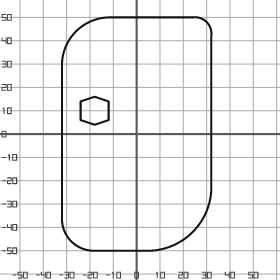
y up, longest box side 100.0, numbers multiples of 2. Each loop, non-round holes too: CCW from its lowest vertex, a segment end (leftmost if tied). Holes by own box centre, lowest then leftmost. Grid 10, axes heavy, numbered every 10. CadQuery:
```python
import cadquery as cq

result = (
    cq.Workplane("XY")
    .moveTo(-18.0, -50.0)
    .lineTo(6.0, -50.0)
    .threePointArc((24.0, -42.0), (32.0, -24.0))
    .lineTo(32.0, 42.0)
    .threePointArc((30.0, 48.0), (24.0, 50.0))
    .lineTo(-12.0, 50.0)
    .threePointArc((-26.0, 44.0), (-32.0, 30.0))
    .lineTo(-32.0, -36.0)
    .threePointArc((-28.0, -46.0), (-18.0, -50.0))
    .close()
    .moveTo(-18.0, 4.0)
    .lineTo(-12.0, 6.0)
    .lineTo(-12.0, 14.0)
    .lineTo(-18.0, 16.0)
    .lineTo(-24.0, 14.0)
    .lineTo(-24.0, 6.0)
    .close()
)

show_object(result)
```